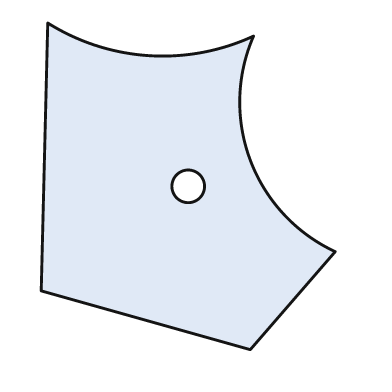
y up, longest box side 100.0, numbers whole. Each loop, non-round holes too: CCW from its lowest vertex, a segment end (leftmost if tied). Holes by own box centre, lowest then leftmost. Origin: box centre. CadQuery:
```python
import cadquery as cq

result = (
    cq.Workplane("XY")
    .moveTo(19.0, -50.0)
    .lineTo(45.0, -20.0)
    .threePointArc((19.0, 8.0), (20.0, 46.0))
    .threePointArc((-12.0, 40.0), (-43.0, 50.0))
    .lineTo(-45.0, -32.0)
    .close()
    .moveTo(0.0, 0.0)
    .circle(5.0)
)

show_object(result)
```